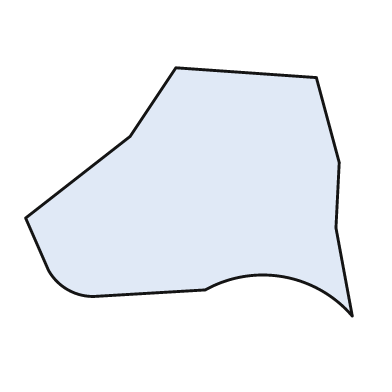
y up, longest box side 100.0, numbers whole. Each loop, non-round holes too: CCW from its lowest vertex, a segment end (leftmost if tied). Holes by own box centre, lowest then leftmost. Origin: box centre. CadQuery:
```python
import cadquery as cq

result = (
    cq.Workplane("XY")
    .moveTo(50.0, -38.0)
    .lineTo(45.0, -11.0)
    .lineTo(46.0, 9.0)
    .lineTo(39.0, 35.0)
    .lineTo(-4.0, 38.0)
    .lineTo(-18.0, 17.0)
    .lineTo(-50.0, -8.0)
    .lineTo(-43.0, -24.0)
    .threePointArc((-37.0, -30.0), (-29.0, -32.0))
    .lineTo(5.0, -30.0)
    .threePointArc((29.0, -26.0), (50.0, -38.0))
    .close()
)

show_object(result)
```